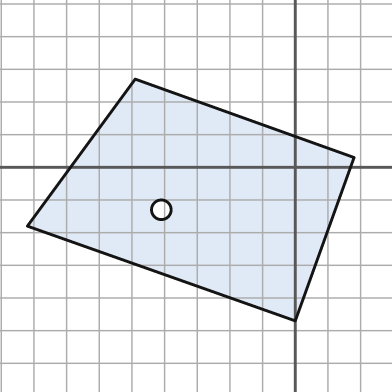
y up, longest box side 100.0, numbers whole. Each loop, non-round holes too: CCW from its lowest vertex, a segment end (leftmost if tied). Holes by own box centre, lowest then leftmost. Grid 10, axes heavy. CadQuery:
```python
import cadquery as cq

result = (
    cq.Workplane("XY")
    .moveTo(0.0, -47.0)
    .lineTo(18.0, 3.0)
    .lineTo(-49.0, 27.0)
    .lineTo(-82.0, -18.0)
    .close()
    .moveTo(-41.0, -13.0)
    .circle(3.0)
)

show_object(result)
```